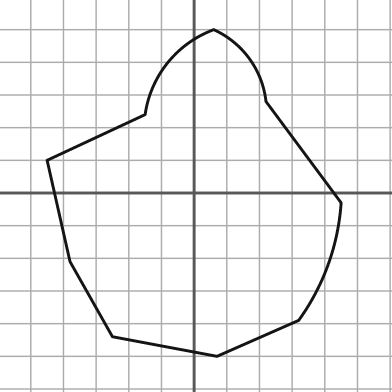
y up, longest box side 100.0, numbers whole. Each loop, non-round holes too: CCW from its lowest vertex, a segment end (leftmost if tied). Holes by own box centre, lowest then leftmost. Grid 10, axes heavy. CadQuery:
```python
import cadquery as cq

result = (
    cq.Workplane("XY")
    .moveTo(7.0, -50.0)
    .lineTo(32.0, -39.0)
    .threePointArc((41.0, -22.0), (45.0, -3.0))
    .lineTo(22.0, 28.0)
    .threePointArc((17.0, 41.0), (6.0, 50.0))
    .threePointArc((-8.0, 40.0), (-15.0, 24.0))
    .lineTo(-45.0, 10.0)
    .lineTo(-38.0, -21.0)
    .lineTo(-25.0, -44.0)
    .close()
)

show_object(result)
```